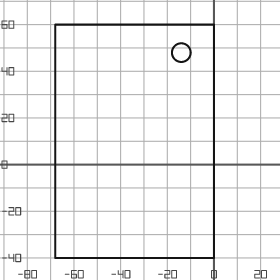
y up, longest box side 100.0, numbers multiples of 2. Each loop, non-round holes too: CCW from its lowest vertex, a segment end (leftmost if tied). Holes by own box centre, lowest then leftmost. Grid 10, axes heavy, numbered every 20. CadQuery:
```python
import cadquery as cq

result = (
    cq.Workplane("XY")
    .moveTo(-68.0, -40.0)
    .lineTo(0.0, -40.0)
    .lineTo(0.0, 60.0)
    .lineTo(-68.0, 60.0)
    .close()
    .moveTo(-14.0, 48.0)
    .circle(4.0)
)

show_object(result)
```